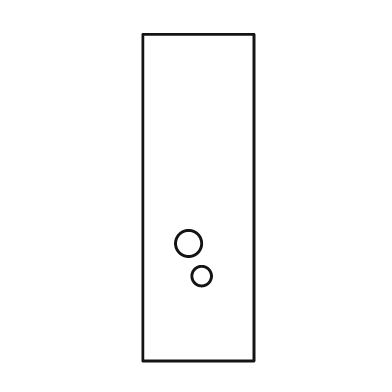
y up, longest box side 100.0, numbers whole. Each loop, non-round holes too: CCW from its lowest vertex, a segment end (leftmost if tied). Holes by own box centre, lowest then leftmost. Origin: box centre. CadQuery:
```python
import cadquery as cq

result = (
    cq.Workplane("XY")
    .moveTo(-17.0, -50.0)
    .lineTo(17.0, -50.0)
    .lineTo(17.0, 50.0)
    .lineTo(-17.0, 50.0)
    .close()
    .moveTo(1.0, -24.0)
    .circle(3.0)
    .moveTo(-3.0, -14.0)
    .circle(4.0)
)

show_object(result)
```